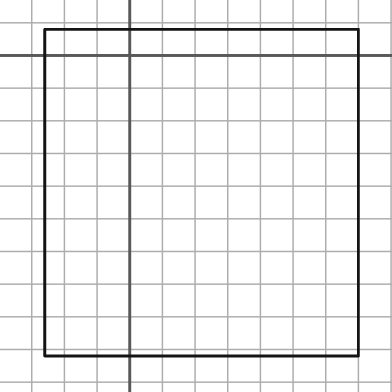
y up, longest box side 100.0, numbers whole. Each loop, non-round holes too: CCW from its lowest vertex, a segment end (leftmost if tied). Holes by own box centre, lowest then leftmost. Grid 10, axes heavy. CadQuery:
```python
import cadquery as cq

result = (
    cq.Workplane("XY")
    .moveTo(-26.0, -92.0)
    .lineTo(70.0, -92.0)
    .lineTo(70.0, 8.0)
    .lineTo(-26.0, 8.0)
    .close()
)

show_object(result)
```